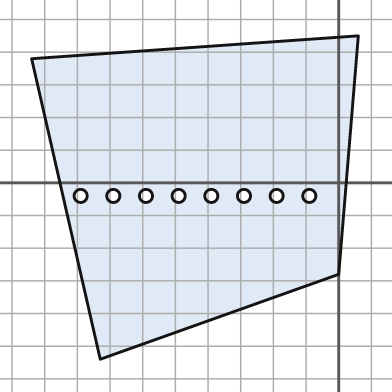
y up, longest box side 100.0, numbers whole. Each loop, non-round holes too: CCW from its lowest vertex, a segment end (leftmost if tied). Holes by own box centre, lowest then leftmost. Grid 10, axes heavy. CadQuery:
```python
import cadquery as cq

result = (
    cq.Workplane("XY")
    .moveTo(-73.0, -54.0)
    .lineTo(0.0, -28.0)
    .lineTo(6.0, 45.0)
    .lineTo(-94.0, 38.0)
    .close()
    .moveTo(-79.0, -4.0)
    .circle(2.0)
    .moveTo(-69.0, -4.0)
    .circle(2.0)
    .moveTo(-59.0, -4.0)
    .circle(2.0)
    .moveTo(-49.0, -4.0)
    .circle(2.0)
    .moveTo(-39.0, -4.0)
    .circle(2.0)
    .moveTo(-29.0, -4.0)
    .circle(2.0)
    .moveTo(-19.0, -4.0)
    .circle(2.0)
    .moveTo(-9.0, -4.0)
    .circle(2.0)
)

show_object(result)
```